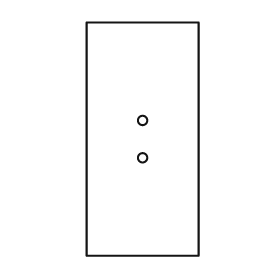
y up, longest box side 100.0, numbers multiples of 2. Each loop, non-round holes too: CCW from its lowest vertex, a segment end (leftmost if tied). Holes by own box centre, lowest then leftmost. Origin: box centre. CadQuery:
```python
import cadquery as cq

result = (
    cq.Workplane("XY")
    .moveTo(-24.0, -50.0)
    .lineTo(24.0, -50.0)
    .lineTo(24.0, 50.0)
    .lineTo(-24.0, 50.0)
    .close()
    .moveTo(0.0, -8.0)
    .circle(2.0)
    .moveTo(0.0, 8.0)
    .circle(2.0)
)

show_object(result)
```